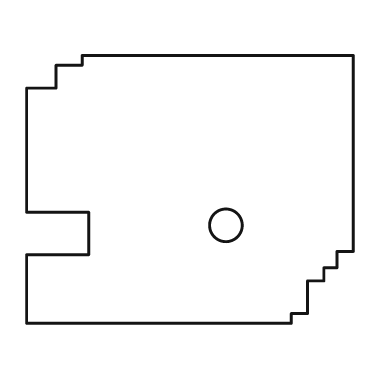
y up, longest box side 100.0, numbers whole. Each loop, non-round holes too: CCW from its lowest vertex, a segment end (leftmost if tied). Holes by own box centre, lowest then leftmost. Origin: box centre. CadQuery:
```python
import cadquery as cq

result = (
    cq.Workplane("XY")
    .moveTo(-50.0, -41.0)
    .lineTo(31.0, -41.0)
    .lineTo(31.0, -38.0)
    .lineTo(36.0, -38.0)
    .lineTo(36.0, -28.0)
    .lineTo(41.0, -28.0)
    .lineTo(41.0, -24.0)
    .lineTo(45.0, -24.0)
    .lineTo(45.0, -19.0)
    .lineTo(50.0, -19.0)
    .lineTo(50.0, 41.0)
    .lineTo(-33.0, 41.0)
    .lineTo(-33.0, 38.0)
    .lineTo(-41.0, 38.0)
    .lineTo(-41.0, 31.0)
    .lineTo(-50.0, 31.0)
    .lineTo(-50.0, -7.0)
    .lineTo(-31.0, -7.0)
    .lineTo(-31.0, -20.0)
    .lineTo(-50.0, -20.0)
    .close()
    .moveTo(11.0, -11.0)
    .circle(5.0)
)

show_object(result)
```